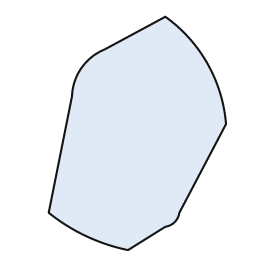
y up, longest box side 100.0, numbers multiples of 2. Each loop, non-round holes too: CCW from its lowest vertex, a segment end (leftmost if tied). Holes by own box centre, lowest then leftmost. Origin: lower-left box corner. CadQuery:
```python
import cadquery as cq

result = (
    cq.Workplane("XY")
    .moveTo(34.0, 0.0)
    .lineTo(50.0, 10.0)
    .threePointArc((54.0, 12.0), (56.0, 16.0))
    .lineTo(76.0, 54.0)
    .threePointArc((68.0, 80.0), (50.0, 100.0))
    .lineTo(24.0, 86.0)
    .threePointArc((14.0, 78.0), (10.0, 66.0))
    .lineTo(0.0, 16.0)
    .threePointArc((16.0, 6.0), (34.0, 0.0))
    .close()
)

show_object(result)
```